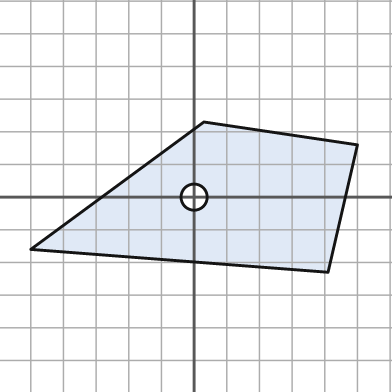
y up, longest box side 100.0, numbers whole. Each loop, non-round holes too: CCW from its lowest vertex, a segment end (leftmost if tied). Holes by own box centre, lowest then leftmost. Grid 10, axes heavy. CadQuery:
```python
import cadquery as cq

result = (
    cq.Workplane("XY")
    .moveTo(41.0, -23.0)
    .lineTo(50.0, 16.0)
    .lineTo(3.0, 23.0)
    .lineTo(-50.0, -16.0)
    .close()
    .moveTo(0.0, 0.0)
    .circle(4.0)
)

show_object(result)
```